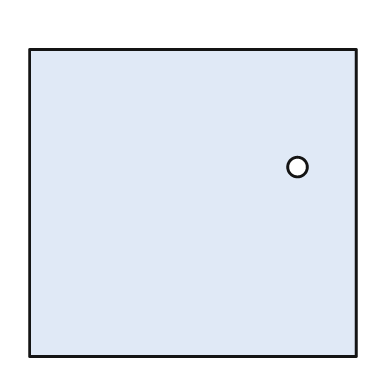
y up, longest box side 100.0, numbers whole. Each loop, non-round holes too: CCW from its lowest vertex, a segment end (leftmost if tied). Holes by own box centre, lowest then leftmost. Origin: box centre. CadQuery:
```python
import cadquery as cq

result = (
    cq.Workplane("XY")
    .moveTo(-50.0, -47.0)
    .lineTo(50.0, -47.0)
    .lineTo(50.0, 47.0)
    .lineTo(-50.0, 47.0)
    .close()
    .moveTo(32.0, 11.0)
    .circle(3.0)
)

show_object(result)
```